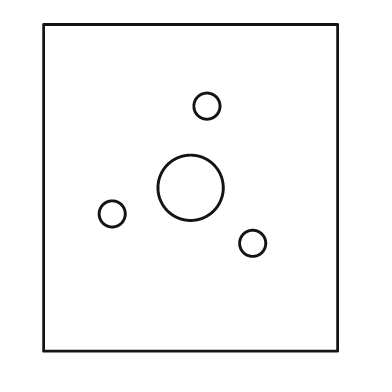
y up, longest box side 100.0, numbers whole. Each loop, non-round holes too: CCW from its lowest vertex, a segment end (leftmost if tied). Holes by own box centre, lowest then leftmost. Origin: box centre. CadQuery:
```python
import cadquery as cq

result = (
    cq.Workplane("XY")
    .moveTo(-45.0, -50.0)
    .lineTo(45.0, -50.0)
    .lineTo(45.0, 50.0)
    .lineTo(-45.0, 50.0)
    .close()
    .moveTo(19.0, -17.0)
    .circle(4.0)
    .moveTo(-24.0, -8.0)
    .circle(4.0)
    .moveTo(0.0, 0.0)
    .circle(10.0)
    .moveTo(5.0, 25.0)
    .circle(4.0)
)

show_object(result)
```